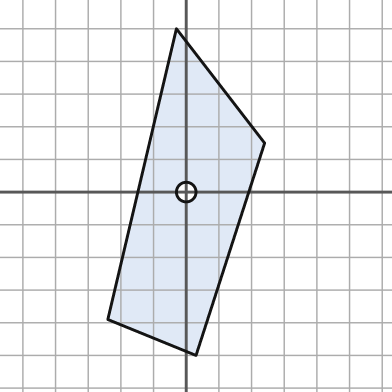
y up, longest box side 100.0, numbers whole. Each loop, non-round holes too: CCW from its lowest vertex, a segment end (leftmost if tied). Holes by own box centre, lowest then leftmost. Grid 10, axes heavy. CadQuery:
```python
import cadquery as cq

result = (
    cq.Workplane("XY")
    .moveTo(3.0, -50.0)
    .lineTo(24.0, 15.0)
    .lineTo(-3.0, 50.0)
    .lineTo(-24.0, -39.0)
    .close()
    .moveTo(0.0, 0.0)
    .circle(3.0)
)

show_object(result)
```